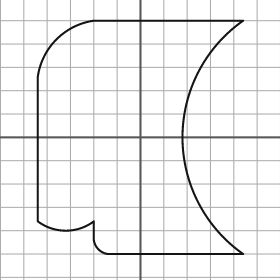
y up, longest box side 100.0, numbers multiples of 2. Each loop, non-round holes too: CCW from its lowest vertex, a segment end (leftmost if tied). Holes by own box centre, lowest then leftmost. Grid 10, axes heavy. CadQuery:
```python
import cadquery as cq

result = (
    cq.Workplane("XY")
    .moveTo(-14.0, -50.0)
    .lineTo(44.0, -50.0)
    .threePointArc((18.0, 0.0), (44.0, 50.0))
    .lineTo(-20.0, 50.0)
    .threePointArc((-36.0, 42.0), (-44.0, 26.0))
    .lineTo(-44.0, -36.0)
    .threePointArc((-32.0, -40.0), (-20.0, -36.0))
    .lineTo(-20.0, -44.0)
    .threePointArc((-18.0, -48.0), (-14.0, -50.0))
    .close()
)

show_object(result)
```